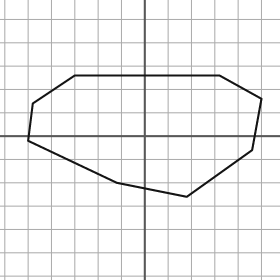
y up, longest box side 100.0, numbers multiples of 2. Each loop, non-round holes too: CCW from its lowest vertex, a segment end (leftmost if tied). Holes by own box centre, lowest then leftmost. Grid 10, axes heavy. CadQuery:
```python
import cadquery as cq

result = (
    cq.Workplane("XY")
    .moveTo(18.0, -26.0)
    .lineTo(46.0, -6.0)
    .lineTo(50.0, 16.0)
    .lineTo(32.0, 26.0)
    .lineTo(-30.0, 26.0)
    .lineTo(-48.0, 14.0)
    .lineTo(-50.0, -2.0)
    .lineTo(-12.0, -20.0)
    .close()
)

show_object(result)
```